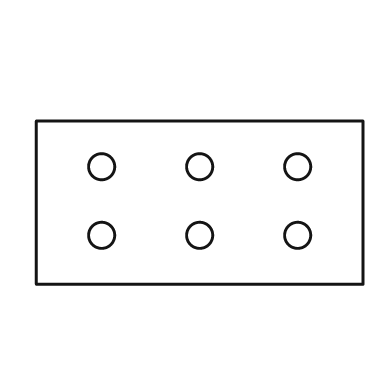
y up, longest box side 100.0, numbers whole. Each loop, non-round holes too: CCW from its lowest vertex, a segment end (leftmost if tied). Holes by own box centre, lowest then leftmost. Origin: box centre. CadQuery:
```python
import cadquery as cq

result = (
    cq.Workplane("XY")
    .moveTo(-50.0, -25.0)
    .lineTo(50.0, -25.0)
    .lineTo(50.0, 25.0)
    .lineTo(-50.0, 25.0)
    .close()
    .moveTo(-30.0, -10.0)
    .circle(4.0)
    .moveTo(0.0, -10.0)
    .circle(4.0)
    .moveTo(30.0, -10.0)
    .circle(4.0)
    .moveTo(-30.0, 11.0)
    .circle(4.0)
    .moveTo(0.0, 11.0)
    .circle(4.0)
    .moveTo(30.0, 11.0)
    .circle(4.0)
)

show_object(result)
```